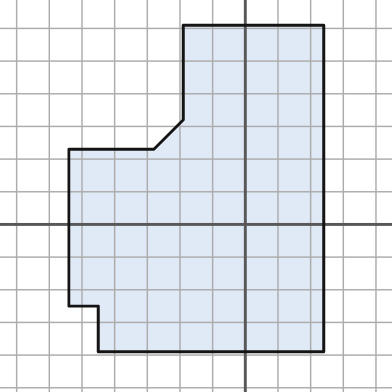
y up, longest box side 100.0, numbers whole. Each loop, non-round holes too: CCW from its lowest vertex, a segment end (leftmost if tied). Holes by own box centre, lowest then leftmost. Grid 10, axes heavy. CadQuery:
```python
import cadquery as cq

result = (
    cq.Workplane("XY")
    .moveTo(-45.0, -39.0)
    .lineTo(24.0, -39.0)
    .lineTo(24.0, 61.0)
    .lineTo(-19.0, 61.0)
    .lineTo(-19.0, 32.0)
    .lineTo(-28.0, 23.0)
    .lineTo(-54.0, 23.0)
    .lineTo(-54.0, -25.0)
    .lineTo(-45.0, -25.0)
    .close()
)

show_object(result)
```